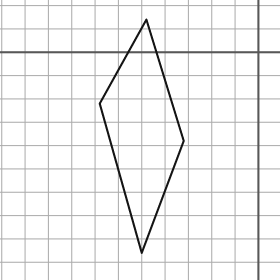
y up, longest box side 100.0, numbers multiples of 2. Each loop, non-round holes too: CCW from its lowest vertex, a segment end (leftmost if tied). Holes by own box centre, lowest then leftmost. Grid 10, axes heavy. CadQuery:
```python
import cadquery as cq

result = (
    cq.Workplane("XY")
    .moveTo(-50.0, -86.0)
    .lineTo(-32.0, -38.0)
    .lineTo(-48.0, 14.0)
    .lineTo(-68.0, -22.0)
    .close()
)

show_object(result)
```